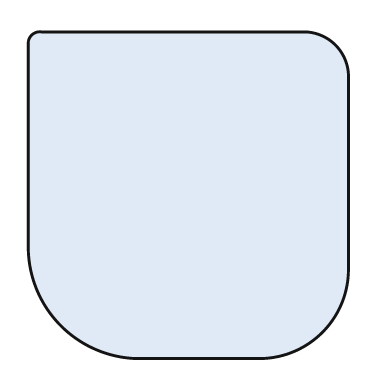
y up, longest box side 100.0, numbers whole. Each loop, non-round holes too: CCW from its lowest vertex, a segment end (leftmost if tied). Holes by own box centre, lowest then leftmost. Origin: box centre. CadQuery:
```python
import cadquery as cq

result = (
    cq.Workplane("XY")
    .moveTo(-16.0, -50.0)
    .lineTo(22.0, -50.0)
    .threePointArc((41.0, -42.0), (49.0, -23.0))
    .lineTo(49.0, 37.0)
    .threePointArc((45.0, 46.0), (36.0, 50.0))
    .lineTo(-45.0, 50.0)
    .threePointArc((-48.0, 49.0), (-49.0, 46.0))
    .lineTo(-49.0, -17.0)
    .threePointArc((-39.0, -40.0), (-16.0, -50.0))
    .close()
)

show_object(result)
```